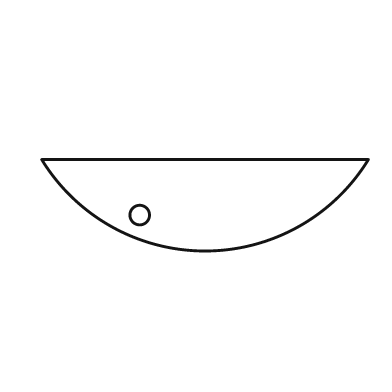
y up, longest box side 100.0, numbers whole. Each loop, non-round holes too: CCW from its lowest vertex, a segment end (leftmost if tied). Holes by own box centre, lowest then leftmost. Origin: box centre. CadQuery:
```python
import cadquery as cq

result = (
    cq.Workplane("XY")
    .moveTo(-50.0, 14.0)
    .threePointArc((0.0, -14.0), (50.0, 14.0))
    .close()
    .moveTo(-20.0, -3.0)
    .circle(3.0)
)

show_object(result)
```